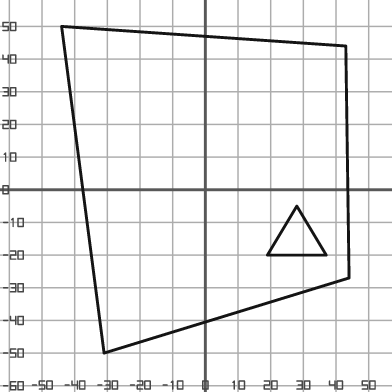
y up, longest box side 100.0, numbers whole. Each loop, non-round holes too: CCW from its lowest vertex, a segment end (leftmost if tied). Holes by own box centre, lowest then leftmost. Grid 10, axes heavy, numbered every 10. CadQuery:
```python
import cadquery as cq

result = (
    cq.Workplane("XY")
    .moveTo(-31.0, -50.0)
    .lineTo(44.0, -27.0)
    .lineTo(43.0, 44.0)
    .lineTo(-44.0, 50.0)
    .close()
    .moveTo(19.0, -20.0)
    .lineTo(37.0, -20.0)
    .lineTo(28.0, -5.0)
    .close()
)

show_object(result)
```